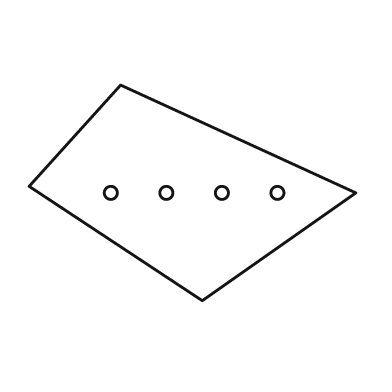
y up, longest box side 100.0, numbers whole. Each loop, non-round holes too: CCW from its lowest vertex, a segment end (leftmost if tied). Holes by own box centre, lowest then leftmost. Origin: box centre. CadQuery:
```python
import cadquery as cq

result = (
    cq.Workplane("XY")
    .moveTo(3.0, -33.0)
    .lineTo(50.0, 0.0)
    .lineTo(-22.0, 33.0)
    .lineTo(-50.0, 2.0)
    .close()
    .moveTo(-25.0, 0.0)
    .circle(2.0)
    .moveTo(-8.0, 0.0)
    .circle(2.0)
    .moveTo(9.0, 0.0)
    .circle(2.0)
    .moveTo(26.0, 0.0)
    .circle(2.0)
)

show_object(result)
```